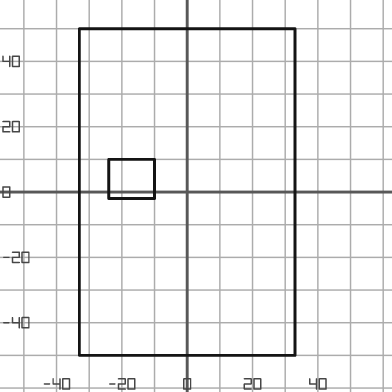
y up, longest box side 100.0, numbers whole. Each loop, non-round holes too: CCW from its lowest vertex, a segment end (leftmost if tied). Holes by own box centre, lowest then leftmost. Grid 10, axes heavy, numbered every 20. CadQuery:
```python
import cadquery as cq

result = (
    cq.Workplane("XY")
    .moveTo(-33.0, -50.0)
    .lineTo(33.0, -50.0)
    .lineTo(33.0, 50.0)
    .lineTo(-33.0, 50.0)
    .close()
    .moveTo(-24.0, -2.0)
    .lineTo(-10.0, -2.0)
    .lineTo(-10.0, 10.0)
    .lineTo(-24.0, 10.0)
    .close()
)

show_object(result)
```